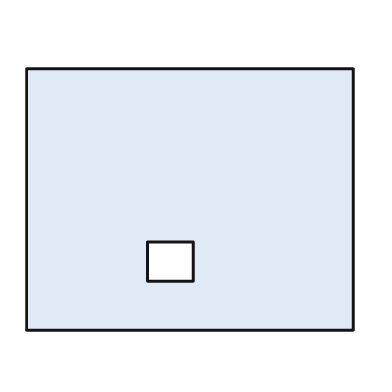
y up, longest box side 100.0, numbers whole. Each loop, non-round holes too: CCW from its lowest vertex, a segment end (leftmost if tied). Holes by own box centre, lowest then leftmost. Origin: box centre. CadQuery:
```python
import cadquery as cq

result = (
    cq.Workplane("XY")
    .moveTo(-50.0, -40.0)
    .lineTo(50.0, -40.0)
    .lineTo(50.0, 40.0)
    .lineTo(-50.0, 40.0)
    .close()
    .moveTo(-13.0, -25.0)
    .lineTo(1.0, -25.0)
    .lineTo(1.0, -13.0)
    .lineTo(-13.0, -13.0)
    .close()
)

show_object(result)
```